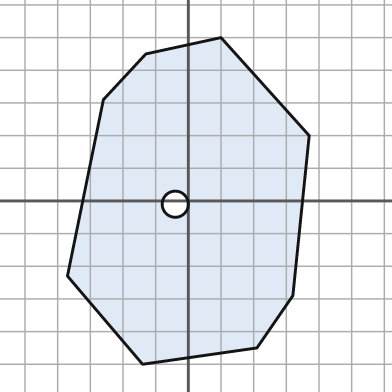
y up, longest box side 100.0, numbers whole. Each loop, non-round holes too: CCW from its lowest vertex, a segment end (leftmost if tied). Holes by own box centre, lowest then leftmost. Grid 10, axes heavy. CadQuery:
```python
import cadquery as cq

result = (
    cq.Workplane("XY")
    .moveTo(-14.0, -50.0)
    .lineTo(21.0, -45.0)
    .lineTo(32.0, -29.0)
    .lineTo(37.0, 20.0)
    .lineTo(10.0, 50.0)
    .lineTo(-13.0, 45.0)
    .lineTo(-26.0, 31.0)
    .lineTo(-37.0, -23.0)
    .close()
    .moveTo(-4.0, -1.0)
    .circle(4.0)
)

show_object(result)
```